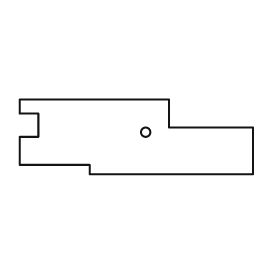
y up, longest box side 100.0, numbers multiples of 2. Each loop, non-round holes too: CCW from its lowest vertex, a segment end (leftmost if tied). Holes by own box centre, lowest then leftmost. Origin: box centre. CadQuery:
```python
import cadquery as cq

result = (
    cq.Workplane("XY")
    .moveTo(-20.0, -16.0)
    .lineTo(50.0, -16.0)
    .lineTo(50.0, 4.0)
    .lineTo(14.0, 4.0)
    .lineTo(14.0, 16.0)
    .lineTo(-50.0, 16.0)
    .lineTo(-50.0, 10.0)
    .lineTo(-42.0, 10.0)
    .lineTo(-42.0, 0.0)
    .lineTo(-50.0, 0.0)
    .lineTo(-50.0, -12.0)
    .lineTo(-20.0, -12.0)
    .close()
    .moveTo(4.0, 2.0)
    .circle(2.0)
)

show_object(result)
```